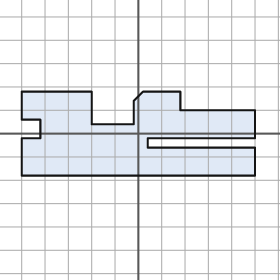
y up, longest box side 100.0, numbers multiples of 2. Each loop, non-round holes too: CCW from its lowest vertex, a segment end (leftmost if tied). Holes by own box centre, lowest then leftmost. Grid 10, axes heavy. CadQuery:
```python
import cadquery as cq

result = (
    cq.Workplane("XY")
    .moveTo(-50.0, -18.0)
    .lineTo(50.0, -18.0)
    .lineTo(50.0, -6.0)
    .lineTo(4.0, -6.0)
    .lineTo(4.0, -2.0)
    .lineTo(50.0, -2.0)
    .lineTo(50.0, 10.0)
    .lineTo(18.0, 10.0)
    .lineTo(18.0, 18.0)
    .lineTo(2.0, 18.0)
    .lineTo(-2.0, 14.0)
    .lineTo(-2.0, 4.0)
    .lineTo(-20.0, 4.0)
    .lineTo(-20.0, 18.0)
    .lineTo(-50.0, 18.0)
    .lineTo(-50.0, 6.0)
    .lineTo(-42.0, 6.0)
    .lineTo(-42.0, -2.0)
    .lineTo(-50.0, -2.0)
    .close()
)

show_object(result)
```